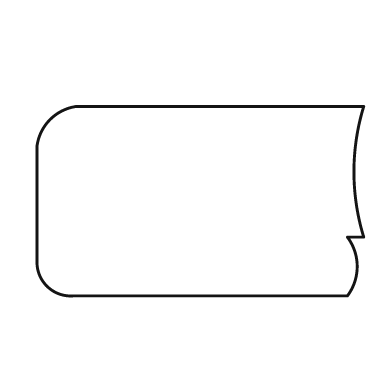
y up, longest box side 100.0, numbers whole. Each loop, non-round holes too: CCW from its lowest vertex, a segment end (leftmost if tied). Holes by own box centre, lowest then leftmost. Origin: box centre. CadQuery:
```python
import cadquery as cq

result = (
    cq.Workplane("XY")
    .moveTo(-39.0, -29.0)
    .lineTo(45.0, -29.0)
    .threePointArc((48.0, -20.0), (45.0, -11.0))
    .lineTo(50.0, -11.0)
    .threePointArc((47.0, 9.0), (50.0, 29.0))
    .lineTo(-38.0, 29.0)
    .threePointArc((-46.0, 25.0), (-50.0, 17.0))
    .lineTo(-50.0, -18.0)
    .threePointArc((-47.0, -26.0), (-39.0, -29.0))
    .close()
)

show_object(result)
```